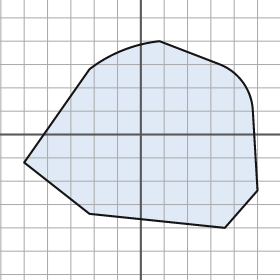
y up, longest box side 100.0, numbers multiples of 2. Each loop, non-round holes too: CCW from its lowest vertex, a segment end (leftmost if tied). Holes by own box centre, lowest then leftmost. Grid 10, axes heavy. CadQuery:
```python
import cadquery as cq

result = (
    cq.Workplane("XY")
    .moveTo(36.0, -40.0)
    .lineTo(50.0, -24.0)
    .lineTo(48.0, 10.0)
    .threePointArc((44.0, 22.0), (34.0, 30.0))
    .lineTo(8.0, 40.0)
    .threePointArc((-8.0, 36.0), (-22.0, 28.0))
    .lineTo(-50.0, -12.0)
    .lineTo(-22.0, -34.0)
    .close()
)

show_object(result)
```